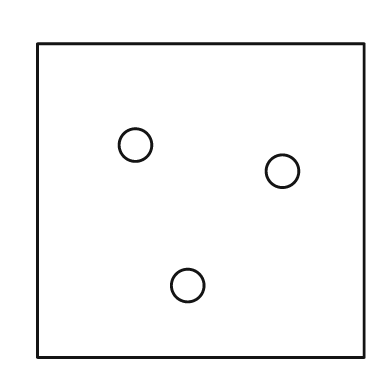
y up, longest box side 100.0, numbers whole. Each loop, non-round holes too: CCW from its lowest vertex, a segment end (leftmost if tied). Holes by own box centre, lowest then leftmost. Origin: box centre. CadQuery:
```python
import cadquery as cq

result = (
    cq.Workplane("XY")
    .moveTo(-50.0, -48.0)
    .lineTo(50.0, -48.0)
    .lineTo(50.0, 48.0)
    .lineTo(-50.0, 48.0)
    .close()
    .moveTo(-4.0, -26.0)
    .circle(5.0)
    .moveTo(25.0, 9.0)
    .circle(5.0)
    .moveTo(-20.0, 17.0)
    .circle(5.0)
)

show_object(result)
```